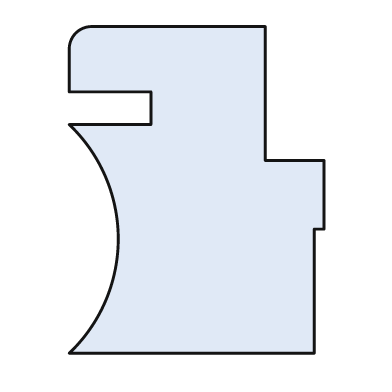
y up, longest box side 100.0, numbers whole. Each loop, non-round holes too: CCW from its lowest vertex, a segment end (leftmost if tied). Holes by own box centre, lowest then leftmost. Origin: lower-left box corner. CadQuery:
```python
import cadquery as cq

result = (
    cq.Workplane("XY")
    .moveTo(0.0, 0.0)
    .lineTo(75.0, 0.0)
    .lineTo(75.0, 38.0)
    .lineTo(78.0, 38.0)
    .lineTo(78.0, 59.0)
    .lineTo(60.0, 59.0)
    .lineTo(60.0, 100.0)
    .lineTo(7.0, 100.0)
    .threePointArc((2.0, 98.0), (0.0, 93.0))
    .lineTo(0.0, 80.0)
    .lineTo(25.0, 80.0)
    .lineTo(25.0, 70.0)
    .lineTo(0.0, 70.0)
    .threePointArc((15.0, 35.0), (0.0, 0.0))
    .close()
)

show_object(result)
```